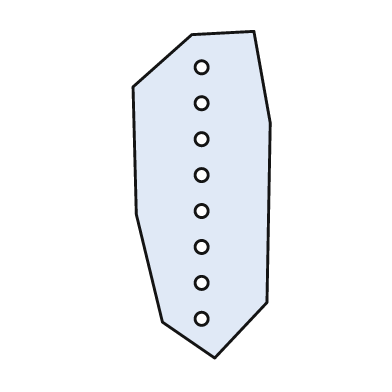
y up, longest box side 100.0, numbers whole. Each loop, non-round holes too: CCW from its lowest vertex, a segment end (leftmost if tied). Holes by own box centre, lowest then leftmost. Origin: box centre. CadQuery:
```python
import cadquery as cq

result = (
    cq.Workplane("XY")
    .moveTo(4.0, -50.0)
    .lineTo(20.0, -33.0)
    .lineTo(21.0, 22.0)
    .lineTo(16.0, 50.0)
    .lineTo(-3.0, 49.0)
    .lineTo(-21.0, 33.0)
    .lineTo(-20.0, -6.0)
    .lineTo(-12.0, -39.0)
    .close()
    .moveTo(0.0, -38.0)
    .circle(2.0)
    .moveTo(0.0, -27.0)
    .circle(2.0)
    .moveTo(0.0, -16.0)
    .circle(2.0)
    .moveTo(0.0, -5.0)
    .circle(2.0)
    .moveTo(0.0, 6.0)
    .circle(2.0)
    .moveTo(0.0, 17.0)
    .circle(2.0)
    .moveTo(0.0, 28.0)
    .circle(2.0)
    .moveTo(0.0, 39.0)
    .circle(2.0)
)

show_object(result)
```